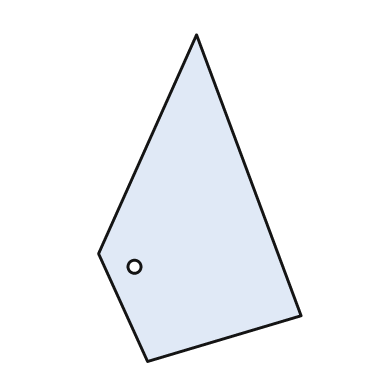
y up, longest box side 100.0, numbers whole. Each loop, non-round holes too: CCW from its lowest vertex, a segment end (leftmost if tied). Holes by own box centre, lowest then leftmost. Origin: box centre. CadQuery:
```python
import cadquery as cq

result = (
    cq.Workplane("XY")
    .moveTo(-16.0, -50.0)
    .lineTo(31.0, -36.0)
    .lineTo(-1.0, 50.0)
    .lineTo(-31.0, -17.0)
    .close()
    .moveTo(-20.0, -21.0)
    .circle(2.0)
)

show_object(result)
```